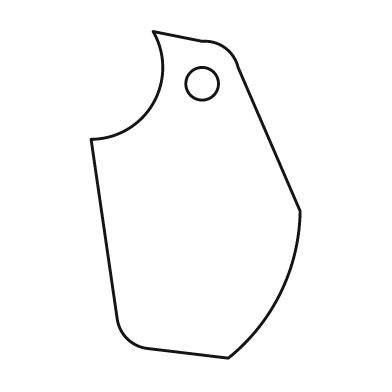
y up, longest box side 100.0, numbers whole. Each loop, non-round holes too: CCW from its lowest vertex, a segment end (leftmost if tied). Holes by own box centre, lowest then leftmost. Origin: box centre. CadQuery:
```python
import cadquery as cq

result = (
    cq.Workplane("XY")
    .moveTo(10.0, -50.0)
    .threePointArc((26.0, -30.0), (32.0, -5.0))
    .lineTo(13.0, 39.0)
    .threePointArc((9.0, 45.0), (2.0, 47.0))
    .lineTo(-13.0, 50.0)
    .threePointArc((-13.0, 28.0), (-32.0, 17.0))
    .lineTo(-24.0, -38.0)
    .threePointArc((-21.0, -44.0), (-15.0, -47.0))
    .close()
    .moveTo(2.0, 34.0)
    .circle(5.0)
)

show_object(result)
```